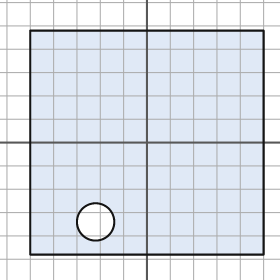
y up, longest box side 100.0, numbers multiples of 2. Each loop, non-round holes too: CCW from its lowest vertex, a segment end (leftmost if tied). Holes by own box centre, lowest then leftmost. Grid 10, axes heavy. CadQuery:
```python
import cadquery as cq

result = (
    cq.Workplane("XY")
    .moveTo(-50.0, -48.0)
    .lineTo(50.0, -48.0)
    .lineTo(50.0, 48.0)
    .lineTo(-50.0, 48.0)
    .close()
    .moveTo(-22.0, -34.0)
    .circle(8.0)
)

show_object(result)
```